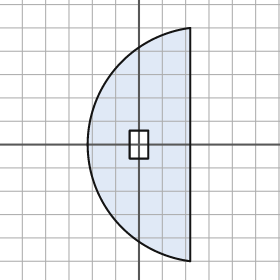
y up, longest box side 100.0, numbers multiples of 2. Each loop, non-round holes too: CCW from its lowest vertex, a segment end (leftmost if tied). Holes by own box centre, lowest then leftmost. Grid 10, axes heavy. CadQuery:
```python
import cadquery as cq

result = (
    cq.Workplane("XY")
    .moveTo(22.0, -50.0)
    .lineTo(22.0, 50.0)
    .threePointArc((-22.0, 0.0), (22.0, -50.0))
    .close()
    .moveTo(-4.0, -6.0)
    .lineTo(4.0, -6.0)
    .lineTo(4.0, 6.0)
    .lineTo(-4.0, 6.0)
    .close()
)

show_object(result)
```